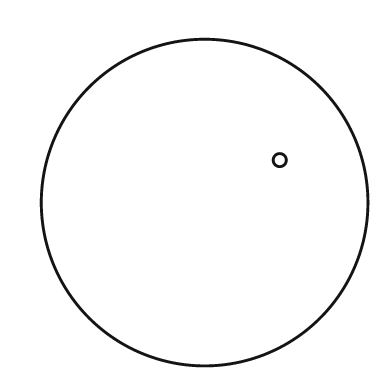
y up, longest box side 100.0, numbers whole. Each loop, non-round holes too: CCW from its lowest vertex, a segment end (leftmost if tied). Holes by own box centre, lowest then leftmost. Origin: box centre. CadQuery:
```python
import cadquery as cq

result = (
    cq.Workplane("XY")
    .moveTo(0.0, 0.0)
    .circle(50.0)
    .moveTo(23.0, 13.0)
    .circle(2.0)
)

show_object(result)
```